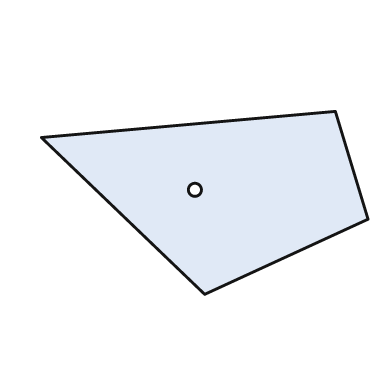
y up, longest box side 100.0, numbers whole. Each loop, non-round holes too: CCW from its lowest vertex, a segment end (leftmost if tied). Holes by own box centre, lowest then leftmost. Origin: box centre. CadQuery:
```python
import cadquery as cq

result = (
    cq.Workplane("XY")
    .moveTo(0.0, -28.0)
    .lineTo(50.0, -5.0)
    .lineTo(40.0, 28.0)
    .lineTo(-50.0, 20.0)
    .close()
    .moveTo(-3.0, 4.0)
    .circle(2.0)
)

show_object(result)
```